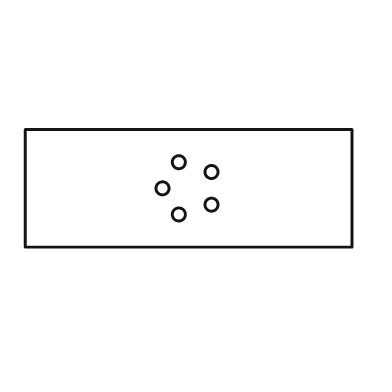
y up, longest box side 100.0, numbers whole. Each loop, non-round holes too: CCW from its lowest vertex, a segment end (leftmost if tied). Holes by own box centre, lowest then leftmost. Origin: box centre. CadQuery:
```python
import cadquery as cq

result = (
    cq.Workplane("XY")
    .moveTo(-50.0, -18.0)
    .lineTo(50.0, -18.0)
    .lineTo(50.0, 18.0)
    .lineTo(-50.0, 18.0)
    .close()
    .moveTo(-3.0, -8.0)
    .circle(2.0)
    .moveTo(7.0, -5.0)
    .circle(2.0)
    .moveTo(-8.0, 0.0)
    .circle(2.0)
    .moveTo(7.0, 5.0)
    .circle(2.0)
    .moveTo(-3.0, 8.0)
    .circle(2.0)
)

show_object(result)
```